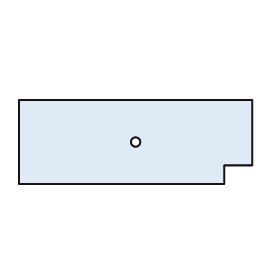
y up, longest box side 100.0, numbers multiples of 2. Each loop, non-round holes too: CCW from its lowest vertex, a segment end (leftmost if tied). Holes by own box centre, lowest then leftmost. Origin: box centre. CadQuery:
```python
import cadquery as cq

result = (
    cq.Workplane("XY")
    .moveTo(-50.0, -18.0)
    .lineTo(38.0, -18.0)
    .lineTo(38.0, -10.0)
    .lineTo(50.0, -10.0)
    .lineTo(50.0, 18.0)
    .lineTo(-50.0, 18.0)
    .close()
    .moveTo(0.0, 0.0)
    .circle(2.0)
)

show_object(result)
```